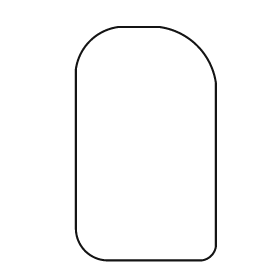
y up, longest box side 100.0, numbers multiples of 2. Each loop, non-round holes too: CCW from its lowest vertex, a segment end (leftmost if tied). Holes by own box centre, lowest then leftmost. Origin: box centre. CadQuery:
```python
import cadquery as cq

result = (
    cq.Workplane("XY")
    .moveTo(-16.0, -50.0)
    .lineTo(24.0, -50.0)
    .threePointArc((28.0, -48.0), (30.0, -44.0))
    .lineTo(30.0, 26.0)
    .threePointArc((22.0, 42.0), (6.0, 50.0))
    .lineTo(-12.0, 50.0)
    .threePointArc((-24.0, 44.0), (-30.0, 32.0))
    .lineTo(-30.0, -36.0)
    .threePointArc((-26.0, -46.0), (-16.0, -50.0))
    .close()
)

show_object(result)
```